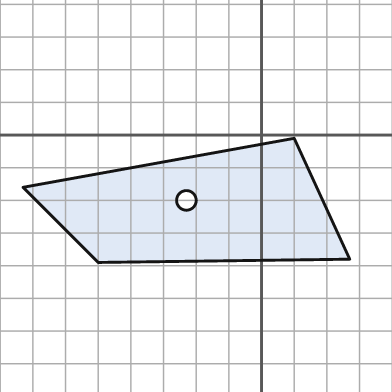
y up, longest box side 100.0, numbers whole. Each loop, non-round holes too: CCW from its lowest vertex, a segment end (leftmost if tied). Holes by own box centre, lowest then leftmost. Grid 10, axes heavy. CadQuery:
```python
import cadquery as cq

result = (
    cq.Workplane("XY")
    .moveTo(-50.0, -39.0)
    .lineTo(27.0, -38.0)
    .lineTo(10.0, -1.0)
    .lineTo(-73.0, -16.0)
    .close()
    .moveTo(-23.0, -20.0)
    .circle(3.0)
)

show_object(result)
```